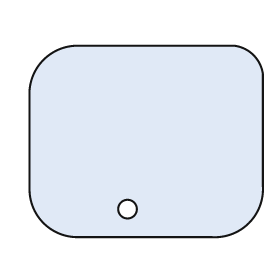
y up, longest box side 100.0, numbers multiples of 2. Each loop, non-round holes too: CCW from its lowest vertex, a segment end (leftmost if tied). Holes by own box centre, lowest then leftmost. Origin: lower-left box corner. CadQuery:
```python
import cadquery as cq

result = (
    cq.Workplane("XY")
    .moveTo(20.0, 0.0)
    .lineTo(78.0, 0.0)
    .threePointArc((94.0, 6.0), (100.0, 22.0))
    .lineTo(100.0, 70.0)
    .threePointArc((96.0, 78.0), (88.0, 82.0))
    .lineTo(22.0, 82.0)
    .threePointArc((6.0, 76.0), (0.0, 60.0))
    .lineTo(0.0, 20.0)
    .threePointArc((6.0, 6.0), (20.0, 0.0))
    .close()
    .moveTo(42.0, 12.0)
    .circle(4.0)
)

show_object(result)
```